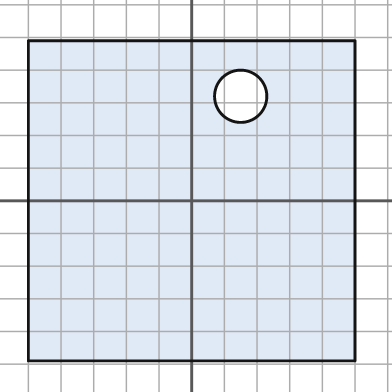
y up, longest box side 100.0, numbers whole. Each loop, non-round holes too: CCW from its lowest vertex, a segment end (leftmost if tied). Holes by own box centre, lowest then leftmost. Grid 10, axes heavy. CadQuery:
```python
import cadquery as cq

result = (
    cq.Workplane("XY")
    .moveTo(-50.0, -49.0)
    .lineTo(50.0, -49.0)
    .lineTo(50.0, 49.0)
    .lineTo(-50.0, 49.0)
    .close()
    .moveTo(15.0, 32.0)
    .circle(8.0)
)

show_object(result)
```